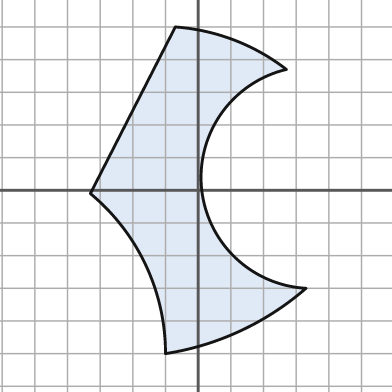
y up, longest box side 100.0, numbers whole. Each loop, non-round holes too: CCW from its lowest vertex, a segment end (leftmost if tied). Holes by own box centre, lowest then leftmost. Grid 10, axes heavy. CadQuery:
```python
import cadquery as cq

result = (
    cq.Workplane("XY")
    .moveTo(-10.0, -50.0)
    .threePointArc((13.0, -43.0), (33.0, -30.0))
    .threePointArc((1.0, 1.0), (27.0, 37.0))
    .threePointArc((11.0, 46.0), (-7.0, 50.0))
    .lineTo(-33.0, -1.0)
    .threePointArc((-16.0, -23.0), (-10.0, -50.0))
    .close()
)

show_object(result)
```